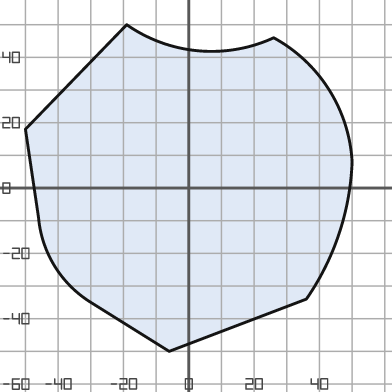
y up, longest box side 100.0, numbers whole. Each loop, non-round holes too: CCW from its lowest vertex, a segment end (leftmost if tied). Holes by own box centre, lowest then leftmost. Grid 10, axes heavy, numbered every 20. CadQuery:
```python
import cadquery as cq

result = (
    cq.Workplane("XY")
    .moveTo(-6.0, -50.0)
    .lineTo(36.0, -34.0)
    .threePointArc((46.0, -14.0), (50.0, 8.0))
    .threePointArc((43.0, 30.0), (26.0, 46.0))
    .threePointArc((3.0, 42.0), (-19.0, 50.0))
    .lineTo(-50.0, 18.0)
    .lineTo(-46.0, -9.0)
    .threePointArc((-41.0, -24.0), (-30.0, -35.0))
    .close()
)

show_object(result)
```